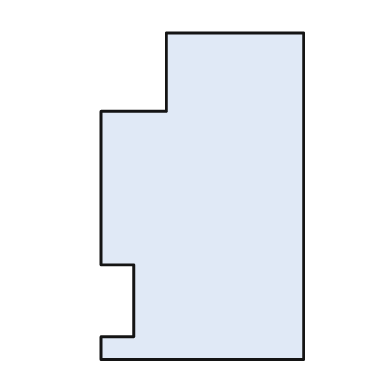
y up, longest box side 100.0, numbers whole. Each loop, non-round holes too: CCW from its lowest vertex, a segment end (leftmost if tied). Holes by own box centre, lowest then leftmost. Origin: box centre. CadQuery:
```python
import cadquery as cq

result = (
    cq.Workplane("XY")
    .moveTo(-31.0, -50.0)
    .lineTo(31.0, -50.0)
    .lineTo(31.0, 50.0)
    .lineTo(-11.0, 50.0)
    .lineTo(-11.0, 26.0)
    .lineTo(-31.0, 26.0)
    .lineTo(-31.0, -21.0)
    .lineTo(-21.0, -21.0)
    .lineTo(-21.0, -43.0)
    .lineTo(-31.0, -43.0)
    .close()
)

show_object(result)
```